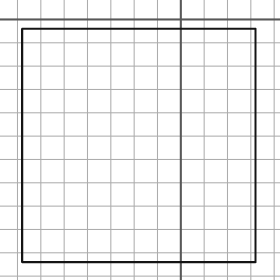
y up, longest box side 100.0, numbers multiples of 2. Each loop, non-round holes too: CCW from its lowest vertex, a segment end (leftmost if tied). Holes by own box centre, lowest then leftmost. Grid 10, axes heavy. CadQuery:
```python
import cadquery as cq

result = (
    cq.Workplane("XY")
    .moveTo(-68.0, -104.0)
    .lineTo(32.0, -104.0)
    .lineTo(32.0, -4.0)
    .lineTo(-68.0, -4.0)
    .close()
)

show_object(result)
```